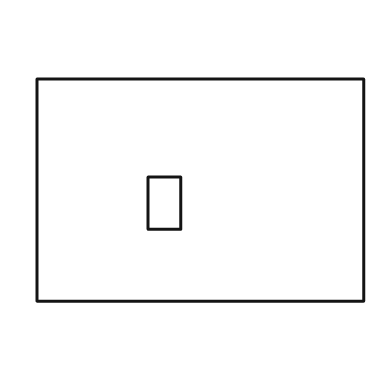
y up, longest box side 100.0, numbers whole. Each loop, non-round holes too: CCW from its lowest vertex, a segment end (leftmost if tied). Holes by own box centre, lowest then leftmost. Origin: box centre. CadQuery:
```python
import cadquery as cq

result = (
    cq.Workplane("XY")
    .moveTo(-50.0, -34.0)
    .lineTo(50.0, -34.0)
    .lineTo(50.0, 34.0)
    .lineTo(-50.0, 34.0)
    .close()
    .moveTo(-16.0, -12.0)
    .lineTo(-6.0, -12.0)
    .lineTo(-6.0, 4.0)
    .lineTo(-16.0, 4.0)
    .close()
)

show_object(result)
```